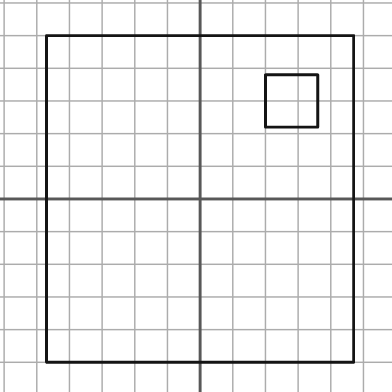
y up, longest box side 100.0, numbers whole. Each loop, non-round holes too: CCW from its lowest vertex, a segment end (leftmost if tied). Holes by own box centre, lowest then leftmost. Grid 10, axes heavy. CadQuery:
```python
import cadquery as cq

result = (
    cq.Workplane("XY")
    .moveTo(-47.0, -50.0)
    .lineTo(47.0, -50.0)
    .lineTo(47.0, 50.0)
    .lineTo(-47.0, 50.0)
    .close()
    .moveTo(20.0, 22.0)
    .lineTo(36.0, 22.0)
    .lineTo(36.0, 38.0)
    .lineTo(20.0, 38.0)
    .close()
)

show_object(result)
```